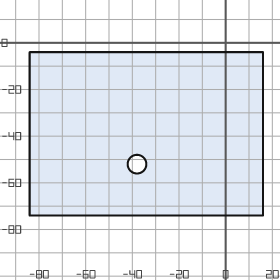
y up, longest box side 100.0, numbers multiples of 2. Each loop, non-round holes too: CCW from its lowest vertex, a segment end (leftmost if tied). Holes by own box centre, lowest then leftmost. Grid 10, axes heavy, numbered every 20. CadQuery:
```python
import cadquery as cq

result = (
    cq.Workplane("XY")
    .moveTo(-84.0, -74.0)
    .lineTo(16.0, -74.0)
    .lineTo(16.0, -4.0)
    .lineTo(-84.0, -4.0)
    .close()
    .moveTo(-38.0, -52.0)
    .circle(4.0)
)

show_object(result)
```